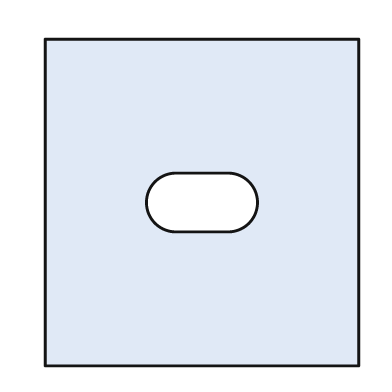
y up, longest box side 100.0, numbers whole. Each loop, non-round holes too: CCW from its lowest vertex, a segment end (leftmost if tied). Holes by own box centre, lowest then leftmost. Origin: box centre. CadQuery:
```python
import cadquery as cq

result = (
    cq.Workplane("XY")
    .moveTo(-48.0, -50.0)
    .lineTo(48.0, -50.0)
    .lineTo(48.0, 50.0)
    .lineTo(-48.0, 50.0)
    .close()
    .moveTo(-8.0, -9.0)
    .lineTo(8.0, -9.0)
    .threePointArc((17.0, 0.0), (8.0, 9.0))
    .lineTo(-8.0, 9.0)
    .threePointArc((-17.0, 0.0), (-8.0, -9.0))
    .close()
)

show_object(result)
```